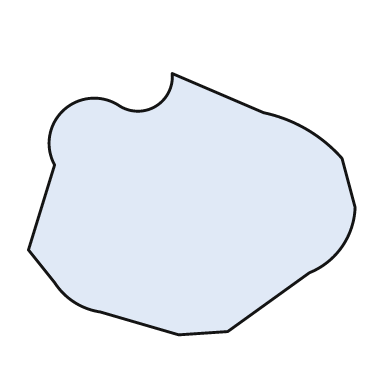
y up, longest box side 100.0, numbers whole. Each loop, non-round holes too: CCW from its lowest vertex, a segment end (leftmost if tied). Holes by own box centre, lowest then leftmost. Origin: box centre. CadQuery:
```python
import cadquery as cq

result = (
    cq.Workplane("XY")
    .moveTo(-4.0, -40.0)
    .lineTo(11.0, -39.0)
    .lineTo(36.0, -21.0)
    .threePointArc((46.0, -13.0), (50.0, -1.0))
    .lineTo(46.0, 14.0)
    .threePointArc((35.0, 23.0), (22.0, 28.0))
    .lineTo(-6.0, 40.0)
    .threePointArc((-11.0, 30.0), (-22.0, 30.0))
    .threePointArc((-39.0, 29.0), (-42.0, 12.0))
    .lineTo(-50.0, -14.0)
    .lineTo(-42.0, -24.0)
    .threePointArc((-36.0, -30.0), (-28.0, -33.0))
    .close()
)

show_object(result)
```